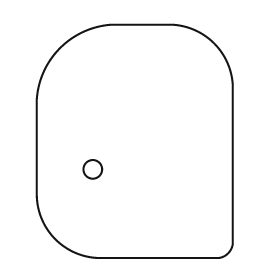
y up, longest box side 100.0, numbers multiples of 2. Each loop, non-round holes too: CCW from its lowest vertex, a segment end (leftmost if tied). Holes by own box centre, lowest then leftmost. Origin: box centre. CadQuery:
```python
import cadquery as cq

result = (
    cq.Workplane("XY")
    .moveTo(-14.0, -50.0)
    .lineTo(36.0, -50.0)
    .threePointArc((40.0, -48.0), (42.0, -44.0))
    .lineTo(42.0, 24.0)
    .threePointArc((34.0, 42.0), (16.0, 50.0))
    .lineTo(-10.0, 50.0)
    .threePointArc((-32.0, 40.0), (-42.0, 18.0))
    .lineTo(-42.0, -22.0)
    .threePointArc((-34.0, -42.0), (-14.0, -50.0))
    .close()
    .moveTo(-18.0, -12.0)
    .circle(4.0)
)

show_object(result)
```